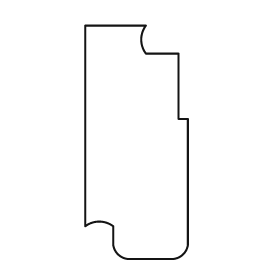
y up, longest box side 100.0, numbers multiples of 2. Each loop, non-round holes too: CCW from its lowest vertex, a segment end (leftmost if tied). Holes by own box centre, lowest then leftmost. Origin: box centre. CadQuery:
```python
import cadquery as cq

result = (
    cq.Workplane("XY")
    .moveTo(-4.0, -50.0)
    .lineTo(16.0, -50.0)
    .threePointArc((20.0, -48.0), (22.0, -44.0))
    .lineTo(22.0, 10.0)
    .lineTo(18.0, 10.0)
    .lineTo(18.0, 38.0)
    .lineTo(4.0, 38.0)
    .threePointArc((2.0, 44.0), (4.0, 50.0))
    .lineTo(-22.0, 50.0)
    .lineTo(-22.0, -36.0)
    .threePointArc((-16.0, -34.0), (-10.0, -36.0))
    .lineTo(-10.0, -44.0)
    .threePointArc((-8.0, -48.0), (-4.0, -50.0))
    .close()
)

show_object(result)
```